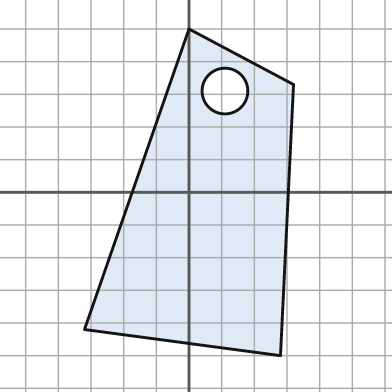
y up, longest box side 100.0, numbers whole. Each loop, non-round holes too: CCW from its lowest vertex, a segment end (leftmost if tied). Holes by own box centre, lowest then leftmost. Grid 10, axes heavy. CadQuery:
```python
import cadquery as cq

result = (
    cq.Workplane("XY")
    .moveTo(28.0, -50.0)
    .lineTo(32.0, 33.0)
    .lineTo(0.0, 50.0)
    .lineTo(-32.0, -42.0)
    .close()
    .moveTo(11.0, 31.0)
    .circle(7.0)
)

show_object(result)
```